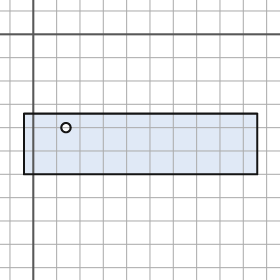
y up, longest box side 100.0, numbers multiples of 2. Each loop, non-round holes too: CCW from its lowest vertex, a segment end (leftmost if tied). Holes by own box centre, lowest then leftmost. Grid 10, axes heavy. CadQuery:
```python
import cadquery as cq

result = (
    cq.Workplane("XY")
    .moveTo(-4.0, -60.0)
    .lineTo(96.0, -60.0)
    .lineTo(96.0, -34.0)
    .lineTo(-4.0, -34.0)
    .close()
    .moveTo(14.0, -40.0)
    .circle(2.0)
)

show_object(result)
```